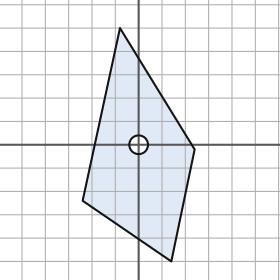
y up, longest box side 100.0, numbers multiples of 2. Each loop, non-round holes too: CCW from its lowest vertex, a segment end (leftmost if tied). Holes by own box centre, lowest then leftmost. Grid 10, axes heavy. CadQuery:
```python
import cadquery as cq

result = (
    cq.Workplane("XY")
    .moveTo(14.0, -50.0)
    .lineTo(24.0, -2.0)
    .lineTo(-8.0, 50.0)
    .lineTo(-24.0, -24.0)
    .close()
    .moveTo(0.0, 0.0)
    .circle(4.0)
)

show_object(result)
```